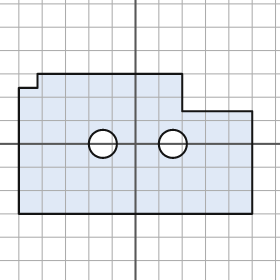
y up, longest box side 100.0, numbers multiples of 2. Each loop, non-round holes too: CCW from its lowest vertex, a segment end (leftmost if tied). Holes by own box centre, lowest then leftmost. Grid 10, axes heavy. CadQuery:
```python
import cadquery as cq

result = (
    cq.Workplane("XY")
    .moveTo(-50.0, -30.0)
    .lineTo(50.0, -30.0)
    .lineTo(50.0, 14.0)
    .lineTo(20.0, 14.0)
    .lineTo(20.0, 30.0)
    .lineTo(-42.0, 30.0)
    .lineTo(-42.0, 24.0)
    .lineTo(-50.0, 24.0)
    .close()
    .moveTo(-14.0, 0.0)
    .circle(6.0)
    .moveTo(16.0, 0.0)
    .circle(6.0)
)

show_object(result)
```